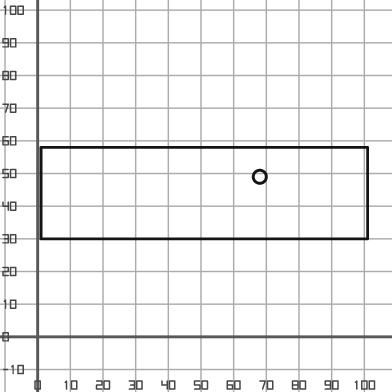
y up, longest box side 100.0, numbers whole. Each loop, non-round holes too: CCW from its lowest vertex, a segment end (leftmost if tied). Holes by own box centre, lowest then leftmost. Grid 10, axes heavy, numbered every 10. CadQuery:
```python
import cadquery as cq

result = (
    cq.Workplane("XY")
    .moveTo(1.0, 30.0)
    .lineTo(101.0, 30.0)
    .lineTo(101.0, 58.0)
    .lineTo(1.0, 58.0)
    .close()
    .moveTo(68.0, 49.0)
    .circle(2.0)
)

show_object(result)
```